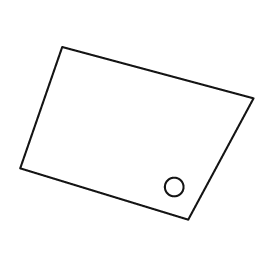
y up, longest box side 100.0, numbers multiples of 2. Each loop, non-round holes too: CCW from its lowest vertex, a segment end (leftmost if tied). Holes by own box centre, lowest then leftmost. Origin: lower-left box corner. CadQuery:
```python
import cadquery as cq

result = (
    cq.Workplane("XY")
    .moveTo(72.0, 0.0)
    .lineTo(100.0, 52.0)
    .lineTo(18.0, 74.0)
    .lineTo(0.0, 22.0)
    .close()
    .moveTo(66.0, 14.0)
    .circle(4.0)
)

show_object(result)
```